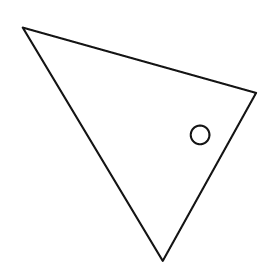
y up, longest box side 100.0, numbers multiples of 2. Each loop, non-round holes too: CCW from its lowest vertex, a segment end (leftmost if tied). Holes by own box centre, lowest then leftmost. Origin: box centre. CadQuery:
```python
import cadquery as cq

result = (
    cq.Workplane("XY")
    .moveTo(10.0, -50.0)
    .lineTo(50.0, 22.0)
    .lineTo(-50.0, 50.0)
    .close()
    .moveTo(26.0, 4.0)
    .circle(4.0)
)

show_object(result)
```